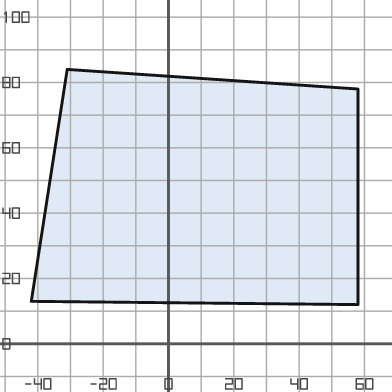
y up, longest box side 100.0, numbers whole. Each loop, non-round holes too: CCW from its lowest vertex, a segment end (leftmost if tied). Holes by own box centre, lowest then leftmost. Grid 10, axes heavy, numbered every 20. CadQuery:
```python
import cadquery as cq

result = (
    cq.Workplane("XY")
    .moveTo(58.0, 12.0)
    .lineTo(58.0, 78.0)
    .lineTo(-31.0, 84.0)
    .lineTo(-42.0, 13.0)
    .close()
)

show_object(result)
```